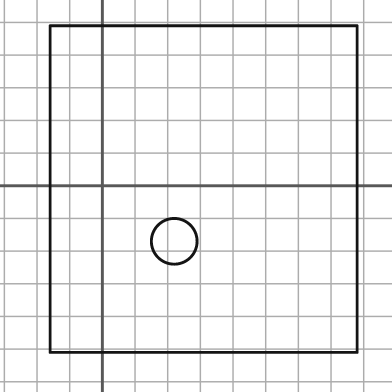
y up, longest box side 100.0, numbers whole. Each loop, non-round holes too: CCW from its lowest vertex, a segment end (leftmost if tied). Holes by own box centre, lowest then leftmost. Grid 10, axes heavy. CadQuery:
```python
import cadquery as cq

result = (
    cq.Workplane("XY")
    .moveTo(-16.0, -51.0)
    .lineTo(78.0, -51.0)
    .lineTo(78.0, 49.0)
    .lineTo(-16.0, 49.0)
    .close()
    .moveTo(22.0, -17.0)
    .circle(7.0)
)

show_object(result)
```